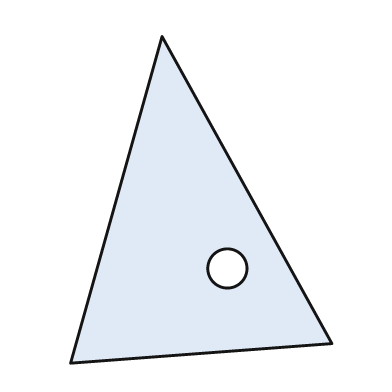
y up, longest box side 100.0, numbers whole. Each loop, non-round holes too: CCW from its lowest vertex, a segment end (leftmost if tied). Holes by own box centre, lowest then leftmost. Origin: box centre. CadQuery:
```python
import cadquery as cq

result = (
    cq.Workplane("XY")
    .moveTo(-40.0, -50.0)
    .lineTo(40.0, -44.0)
    .lineTo(-12.0, 50.0)
    .close()
    .moveTo(8.0, -21.0)
    .circle(6.0)
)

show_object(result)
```